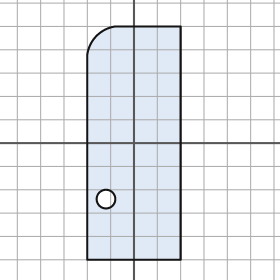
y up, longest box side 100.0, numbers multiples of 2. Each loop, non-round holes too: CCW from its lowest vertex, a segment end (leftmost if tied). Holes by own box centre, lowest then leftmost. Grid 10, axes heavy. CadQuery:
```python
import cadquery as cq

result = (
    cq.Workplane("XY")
    .moveTo(-20.0, -50.0)
    .lineTo(20.0, -50.0)
    .lineTo(20.0, 50.0)
    .lineTo(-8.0, 50.0)
    .threePointArc((-16.0, 46.0), (-20.0, 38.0))
    .close()
    .moveTo(-12.0, -24.0)
    .circle(4.0)
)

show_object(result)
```